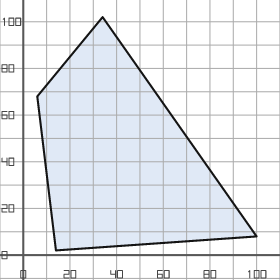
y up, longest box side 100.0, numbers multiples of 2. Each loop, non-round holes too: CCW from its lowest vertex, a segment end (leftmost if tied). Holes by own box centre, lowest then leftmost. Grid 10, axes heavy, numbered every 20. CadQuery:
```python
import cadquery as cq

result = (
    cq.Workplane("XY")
    .moveTo(14.0, 2.0)
    .lineTo(100.0, 8.0)
    .lineTo(34.0, 102.0)
    .lineTo(6.0, 68.0)
    .close()
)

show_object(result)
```